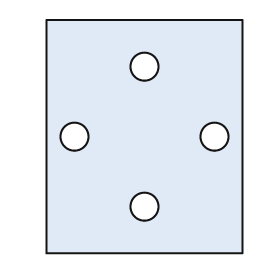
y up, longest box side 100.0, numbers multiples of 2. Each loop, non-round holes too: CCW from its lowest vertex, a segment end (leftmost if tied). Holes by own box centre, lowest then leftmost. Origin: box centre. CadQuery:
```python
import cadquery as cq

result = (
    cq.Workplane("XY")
    .moveTo(-42.0, -50.0)
    .lineTo(42.0, -50.0)
    .lineTo(42.0, 50.0)
    .lineTo(-42.0, 50.0)
    .close()
    .moveTo(0.0, -30.0)
    .circle(6.0)
    .moveTo(-30.0, 0.0)
    .circle(6.0)
    .moveTo(30.0, 0.0)
    .circle(6.0)
    .moveTo(0.0, 30.0)
    .circle(6.0)
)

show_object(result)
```